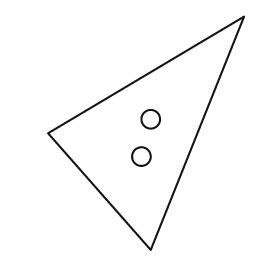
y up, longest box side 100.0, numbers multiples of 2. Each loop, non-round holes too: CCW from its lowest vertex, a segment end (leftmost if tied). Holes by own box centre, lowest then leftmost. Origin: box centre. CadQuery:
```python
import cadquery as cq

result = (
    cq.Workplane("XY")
    .moveTo(2.0, -50.0)
    .lineTo(42.0, 50.0)
    .lineTo(-42.0, 0.0)
    .close()
    .moveTo(-2.0, -10.0)
    .circle(4.0)
    .moveTo(2.0, 6.0)
    .circle(4.0)
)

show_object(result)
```